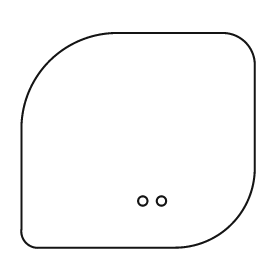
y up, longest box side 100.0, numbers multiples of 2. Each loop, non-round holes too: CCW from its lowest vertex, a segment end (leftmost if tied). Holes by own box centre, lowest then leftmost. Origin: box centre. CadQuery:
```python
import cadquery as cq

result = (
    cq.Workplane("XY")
    .moveTo(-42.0, -46.0)
    .lineTo(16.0, -46.0)
    .threePointArc((40.0, -36.0), (50.0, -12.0))
    .lineTo(50.0, 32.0)
    .threePointArc((46.0, 42.0), (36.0, 46.0))
    .lineTo(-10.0, 46.0)
    .threePointArc((-38.0, 34.0), (-50.0, 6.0))
    .lineTo(-50.0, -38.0)
    .threePointArc((-48.0, -44.0), (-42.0, -46.0))
    .close()
    .moveTo(2.0, -26.0)
    .circle(2.0)
    .moveTo(10.0, -26.0)
    .circle(2.0)
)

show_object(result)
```